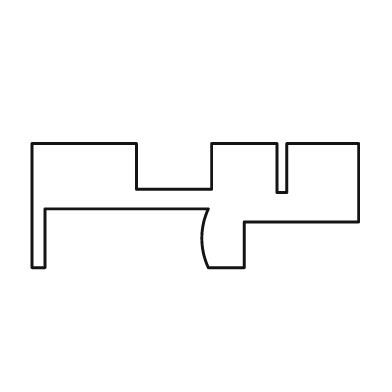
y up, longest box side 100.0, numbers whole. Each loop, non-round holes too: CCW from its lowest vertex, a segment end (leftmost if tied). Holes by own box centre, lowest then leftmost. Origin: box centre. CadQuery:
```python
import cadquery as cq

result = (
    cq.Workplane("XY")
    .moveTo(-50.0, -19.0)
    .lineTo(-46.0, -19.0)
    .lineTo(-46.0, -1.0)
    .lineTo(4.0, -1.0)
    .threePointArc((2.0, -10.0), (4.0, -19.0))
    .lineTo(15.0, -19.0)
    .lineTo(15.0, -5.0)
    .lineTo(50.0, -5.0)
    .lineTo(50.0, 19.0)
    .lineTo(28.0, 19.0)
    .lineTo(28.0, 4.0)
    .lineTo(25.0, 4.0)
    .lineTo(25.0, 19.0)
    .lineTo(5.0, 19.0)
    .lineTo(5.0, 5.0)
    .lineTo(-18.0, 5.0)
    .lineTo(-18.0, 19.0)
    .lineTo(-50.0, 19.0)
    .close()
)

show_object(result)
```